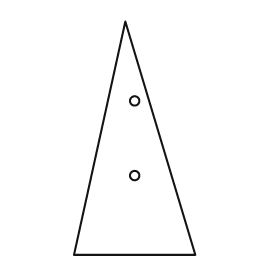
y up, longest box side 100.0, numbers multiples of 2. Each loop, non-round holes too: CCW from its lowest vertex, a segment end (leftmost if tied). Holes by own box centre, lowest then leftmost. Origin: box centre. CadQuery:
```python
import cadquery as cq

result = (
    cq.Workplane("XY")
    .moveTo(-26.0, -50.0)
    .lineTo(26.0, -50.0)
    .lineTo(-4.0, 50.0)
    .close()
    .moveTo(0.0, -16.0)
    .circle(2.0)
    .moveTo(0.0, 16.0)
    .circle(2.0)
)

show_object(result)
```